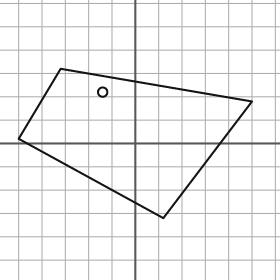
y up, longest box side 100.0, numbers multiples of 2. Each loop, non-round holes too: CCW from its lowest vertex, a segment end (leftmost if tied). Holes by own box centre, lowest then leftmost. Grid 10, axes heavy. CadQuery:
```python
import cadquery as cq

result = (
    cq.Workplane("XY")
    .moveTo(12.0, -32.0)
    .lineTo(50.0, 18.0)
    .lineTo(-32.0, 32.0)
    .lineTo(-50.0, 2.0)
    .close()
    .moveTo(-14.0, 22.0)
    .circle(2.0)
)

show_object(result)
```